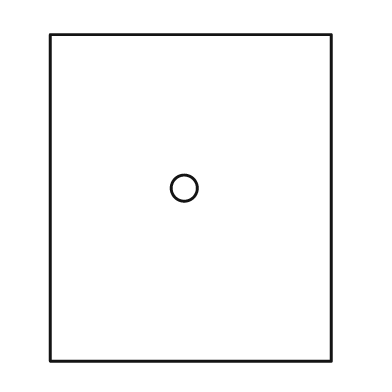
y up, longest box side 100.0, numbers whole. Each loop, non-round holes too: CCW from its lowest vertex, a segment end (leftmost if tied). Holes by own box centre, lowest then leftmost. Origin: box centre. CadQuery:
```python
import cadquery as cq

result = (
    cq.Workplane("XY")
    .moveTo(-43.0, -50.0)
    .lineTo(43.0, -50.0)
    .lineTo(43.0, 50.0)
    .lineTo(-43.0, 50.0)
    .close()
    .moveTo(-2.0, 3.0)
    .circle(4.0)
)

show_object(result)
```